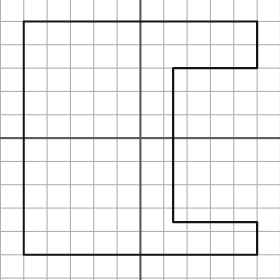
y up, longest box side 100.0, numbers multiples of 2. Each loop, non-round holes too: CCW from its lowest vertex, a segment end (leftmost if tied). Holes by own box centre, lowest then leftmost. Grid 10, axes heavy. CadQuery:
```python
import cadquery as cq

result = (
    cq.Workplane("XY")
    .moveTo(-50.0, -50.0)
    .lineTo(50.0, -50.0)
    .lineTo(50.0, -36.0)
    .lineTo(14.0, -36.0)
    .lineTo(14.0, 30.0)
    .lineTo(50.0, 30.0)
    .lineTo(50.0, 50.0)
    .lineTo(-50.0, 50.0)
    .close()
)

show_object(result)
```